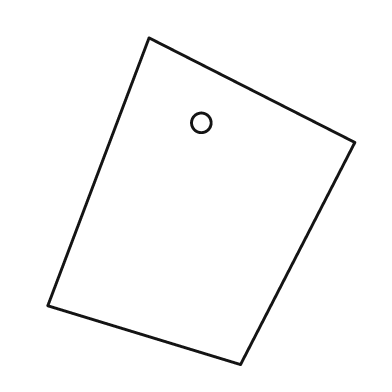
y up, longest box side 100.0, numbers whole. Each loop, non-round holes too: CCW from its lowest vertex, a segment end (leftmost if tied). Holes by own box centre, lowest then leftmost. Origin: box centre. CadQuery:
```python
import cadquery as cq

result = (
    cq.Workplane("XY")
    .moveTo(12.0, -50.0)
    .lineTo(47.0, 18.0)
    .lineTo(-16.0, 50.0)
    .lineTo(-47.0, -32.0)
    .close()
    .moveTo(0.0, 24.0)
    .circle(3.0)
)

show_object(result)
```